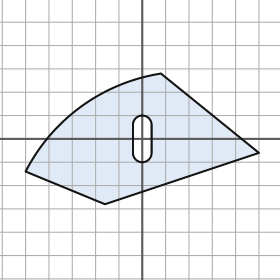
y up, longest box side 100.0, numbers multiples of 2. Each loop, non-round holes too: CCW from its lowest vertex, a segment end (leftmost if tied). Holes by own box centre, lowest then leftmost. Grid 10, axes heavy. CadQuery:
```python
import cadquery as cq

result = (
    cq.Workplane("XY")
    .moveTo(-16.0, -28.0)
    .lineTo(50.0, -6.0)
    .lineTo(8.0, 28.0)
    .threePointArc((-26.0, 14.0), (-50.0, -14.0))
    .close()
    .moveTo(-4.0, -6.0)
    .threePointArc((0.0, -10.0), (4.0, -6.0))
    .lineTo(4.0, 6.0)
    .threePointArc((0.0, 10.0), (-4.0, 6.0))
    .close()
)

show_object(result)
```